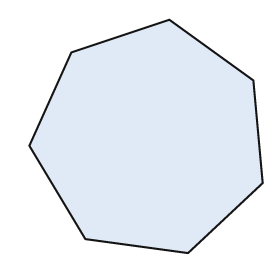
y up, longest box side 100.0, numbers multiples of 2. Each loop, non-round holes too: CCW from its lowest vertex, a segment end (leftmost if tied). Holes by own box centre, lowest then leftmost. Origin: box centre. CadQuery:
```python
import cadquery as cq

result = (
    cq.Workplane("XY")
    .moveTo(18.0, -50.0)
    .lineTo(50.0, -20.0)
    .lineTo(46.0, 24.0)
    .lineTo(10.0, 50.0)
    .lineTo(-32.0, 36.0)
    .lineTo(-50.0, -4.0)
    .lineTo(-26.0, -44.0)
    .close()
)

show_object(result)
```